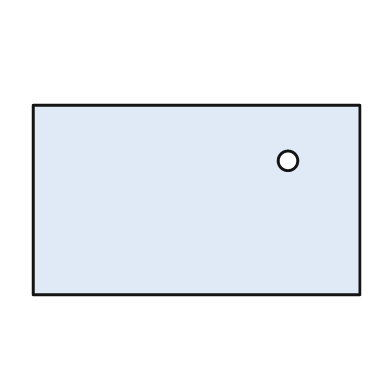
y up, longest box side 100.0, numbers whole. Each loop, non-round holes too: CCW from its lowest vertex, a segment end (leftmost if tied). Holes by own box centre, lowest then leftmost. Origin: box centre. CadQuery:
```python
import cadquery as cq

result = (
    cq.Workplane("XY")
    .moveTo(-50.0, -29.0)
    .lineTo(50.0, -29.0)
    .lineTo(50.0, 29.0)
    .lineTo(-50.0, 29.0)
    .close()
    .moveTo(28.0, 12.0)
    .circle(3.0)
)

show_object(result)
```